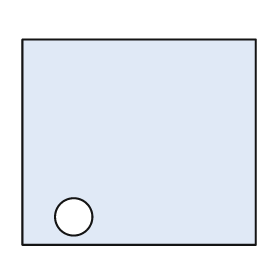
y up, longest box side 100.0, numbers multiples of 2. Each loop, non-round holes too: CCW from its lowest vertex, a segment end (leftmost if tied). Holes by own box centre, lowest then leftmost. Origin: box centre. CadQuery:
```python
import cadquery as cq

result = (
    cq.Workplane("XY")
    .moveTo(-50.0, -44.0)
    .lineTo(50.0, -44.0)
    .lineTo(50.0, 44.0)
    .lineTo(-50.0, 44.0)
    .close()
    .moveTo(-28.0, -32.0)
    .circle(8.0)
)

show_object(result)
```